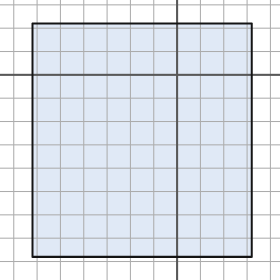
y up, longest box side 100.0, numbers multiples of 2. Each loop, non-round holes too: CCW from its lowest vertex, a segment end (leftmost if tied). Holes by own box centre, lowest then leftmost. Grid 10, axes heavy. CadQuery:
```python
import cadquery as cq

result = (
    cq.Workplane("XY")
    .moveTo(-62.0, -78.0)
    .lineTo(32.0, -78.0)
    .lineTo(32.0, 22.0)
    .lineTo(-62.0, 22.0)
    .close()
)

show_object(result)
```